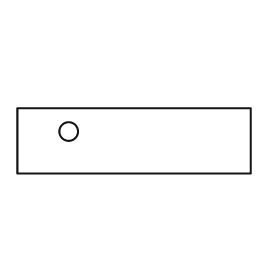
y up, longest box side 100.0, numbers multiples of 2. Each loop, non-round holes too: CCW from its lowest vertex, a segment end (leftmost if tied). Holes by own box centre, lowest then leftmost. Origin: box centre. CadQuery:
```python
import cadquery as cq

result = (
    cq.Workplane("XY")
    .moveTo(-50.0, -14.0)
    .lineTo(50.0, -14.0)
    .lineTo(50.0, 14.0)
    .lineTo(-50.0, 14.0)
    .close()
    .moveTo(-28.0, 4.0)
    .circle(4.0)
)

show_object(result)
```